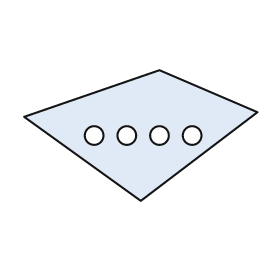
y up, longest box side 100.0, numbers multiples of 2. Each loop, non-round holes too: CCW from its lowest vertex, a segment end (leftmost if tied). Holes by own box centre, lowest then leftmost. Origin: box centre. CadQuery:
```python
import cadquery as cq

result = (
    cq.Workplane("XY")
    .moveTo(0.0, -28.0)
    .lineTo(50.0, 10.0)
    .lineTo(8.0, 28.0)
    .lineTo(-50.0, 8.0)
    .close()
    .moveTo(-20.0, 0.0)
    .circle(4.0)
    .moveTo(-6.0, 0.0)
    .circle(4.0)
    .moveTo(8.0, 0.0)
    .circle(4.0)
    .moveTo(22.0, 0.0)
    .circle(4.0)
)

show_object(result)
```